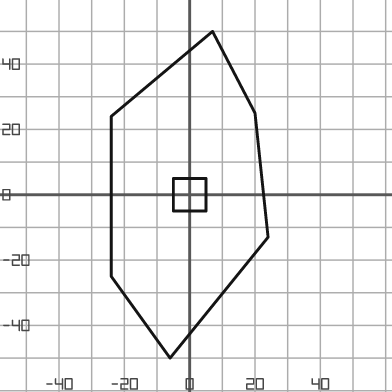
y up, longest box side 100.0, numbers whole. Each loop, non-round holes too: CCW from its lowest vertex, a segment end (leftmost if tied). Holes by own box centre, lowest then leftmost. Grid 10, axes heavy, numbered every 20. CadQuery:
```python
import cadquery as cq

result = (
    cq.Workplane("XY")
    .moveTo(-6.0, -50.0)
    .lineTo(24.0, -13.0)
    .lineTo(20.0, 25.0)
    .lineTo(7.0, 50.0)
    .lineTo(-24.0, 24.0)
    .lineTo(-24.0, -25.0)
    .close()
    .moveTo(-5.0, -5.0)
    .lineTo(5.0, -5.0)
    .lineTo(5.0, 5.0)
    .lineTo(-5.0, 5.0)
    .close()
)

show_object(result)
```